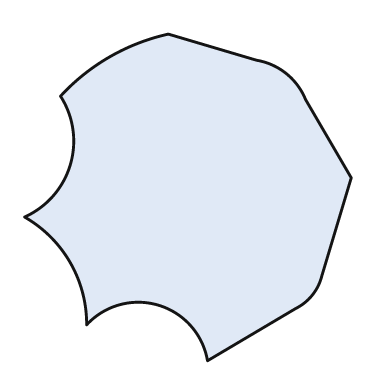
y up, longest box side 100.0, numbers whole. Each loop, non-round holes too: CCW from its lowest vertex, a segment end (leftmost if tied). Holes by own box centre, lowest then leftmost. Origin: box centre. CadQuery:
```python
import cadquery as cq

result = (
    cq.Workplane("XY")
    .moveTo(6.0, -50.0)
    .lineTo(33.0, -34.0)
    .threePointArc((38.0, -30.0), (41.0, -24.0))
    .lineTo(50.0, 6.0)
    .lineTo(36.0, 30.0)
    .threePointArc((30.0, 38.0), (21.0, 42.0))
    .lineTo(-6.0, 50.0)
    .threePointArc((-24.0, 43.0), (-39.0, 31.0))
    .threePointArc((-36.0, 10.0), (-50.0, -6.0))
    .threePointArc((-36.0, -20.0), (-31.0, -39.0))
    .threePointArc((-9.0, -33.0), (6.0, -50.0))
    .close()
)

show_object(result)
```